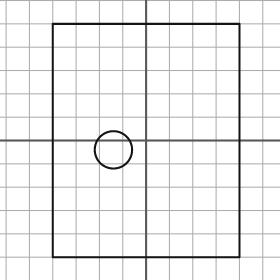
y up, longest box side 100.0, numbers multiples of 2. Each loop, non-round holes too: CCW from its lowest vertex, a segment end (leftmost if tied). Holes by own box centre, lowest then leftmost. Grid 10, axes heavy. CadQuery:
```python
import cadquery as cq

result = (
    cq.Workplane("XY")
    .moveTo(-40.0, -50.0)
    .lineTo(40.0, -50.0)
    .lineTo(40.0, 50.0)
    .lineTo(-40.0, 50.0)
    .close()
    .moveTo(-14.0, -4.0)
    .circle(8.0)
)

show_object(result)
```